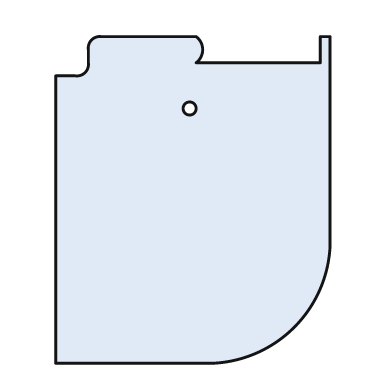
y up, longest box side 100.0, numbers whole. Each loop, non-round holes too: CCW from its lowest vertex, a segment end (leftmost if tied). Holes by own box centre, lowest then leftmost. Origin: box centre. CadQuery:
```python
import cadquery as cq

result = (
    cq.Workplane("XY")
    .moveTo(-42.0, -50.0)
    .lineTo(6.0, -50.0)
    .threePointArc((31.0, -39.0), (42.0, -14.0))
    .lineTo(42.0, 50.0)
    .lineTo(39.0, 50.0)
    .lineTo(39.0, 42.0)
    .lineTo(1.0, 42.0)
    .threePointArc((3.0, 46.0), (1.0, 50.0))
    .lineTo(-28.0, 50.0)
    .threePointArc((-31.0, 49.0), (-32.0, 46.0))
    .lineTo(-32.0, 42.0)
    .threePointArc((-33.0, 39.0), (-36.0, 38.0))
    .lineTo(-42.0, 38.0)
    .close()
    .moveTo(-1.0, 28.0)
    .circle(2.0)
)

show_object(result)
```